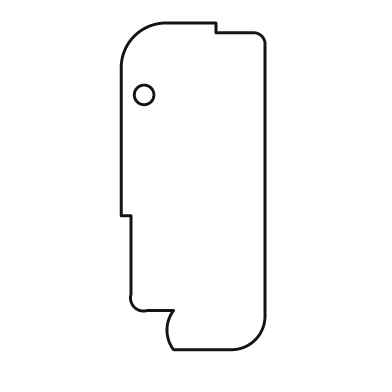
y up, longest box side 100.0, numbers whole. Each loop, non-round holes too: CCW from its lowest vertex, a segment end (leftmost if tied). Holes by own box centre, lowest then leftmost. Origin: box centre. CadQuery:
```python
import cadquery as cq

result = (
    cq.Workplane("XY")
    .moveTo(-6.0, -50.0)
    .lineTo(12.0, -50.0)
    .threePointArc((19.0, -47.0), (22.0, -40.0))
    .lineTo(22.0, 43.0)
    .threePointArc((21.0, 46.0), (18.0, 47.0))
    .lineTo(7.0, 47.0)
    .lineTo(7.0, 50.0)
    .lineTo(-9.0, 50.0)
    .threePointArc((-18.0, 46.0), (-22.0, 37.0))
    .lineTo(-22.0, -9.0)
    .lineTo(-19.0, -9.0)
    .lineTo(-19.0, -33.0)
    .threePointArc((-18.0, -37.0), (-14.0, -38.0))
    .lineTo(-6.0, -38.0)
    .threePointArc((-8.0, -44.0), (-6.0, -50.0))
    .close()
    .moveTo(-15.0, 28.0)
    .circle(3.0)
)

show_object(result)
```